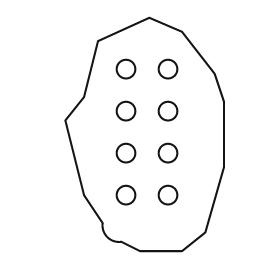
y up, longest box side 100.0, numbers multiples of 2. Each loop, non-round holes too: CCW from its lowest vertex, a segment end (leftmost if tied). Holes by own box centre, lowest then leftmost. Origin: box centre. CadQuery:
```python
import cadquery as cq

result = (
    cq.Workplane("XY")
    .moveTo(-2.0, -50.0)
    .lineTo(16.0, -50.0)
    .lineTo(26.0, -42.0)
    .lineTo(34.0, -14.0)
    .lineTo(34.0, 14.0)
    .lineTo(30.0, 26.0)
    .lineTo(16.0, 44.0)
    .lineTo(2.0, 50.0)
    .lineTo(-20.0, 40.0)
    .lineTo(-26.0, 16.0)
    .lineTo(-34.0, 6.0)
    .lineTo(-26.0, -26.0)
    .lineTo(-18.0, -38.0)
    .threePointArc((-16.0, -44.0), (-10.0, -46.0))
    .close()
    .moveTo(-8.0, -26.0)
    .circle(4.0)
    .moveTo(10.0, -26.0)
    .circle(4.0)
    .moveTo(-8.0, -8.0)
    .circle(4.0)
    .moveTo(10.0, -8.0)
    .circle(4.0)
    .moveTo(-8.0, 10.0)
    .circle(4.0)
    .moveTo(10.0, 10.0)
    .circle(4.0)
    .moveTo(-8.0, 28.0)
    .circle(4.0)
    .moveTo(10.0, 28.0)
    .circle(4.0)
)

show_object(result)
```